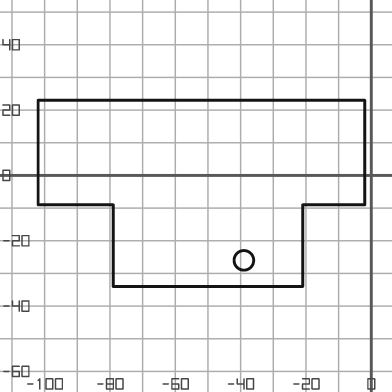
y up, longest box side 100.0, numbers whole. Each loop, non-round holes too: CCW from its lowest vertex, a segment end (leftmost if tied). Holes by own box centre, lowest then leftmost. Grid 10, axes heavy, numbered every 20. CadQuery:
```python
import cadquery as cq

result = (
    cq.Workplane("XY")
    .moveTo(-79.0, -34.0)
    .lineTo(-21.0, -34.0)
    .lineTo(-21.0, -9.0)
    .lineTo(-2.0, -9.0)
    .lineTo(-2.0, 23.0)
    .lineTo(-102.0, 23.0)
    .lineTo(-102.0, -9.0)
    .lineTo(-79.0, -9.0)
    .close()
    .moveTo(-39.0, -26.0)
    .circle(3.0)
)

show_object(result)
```